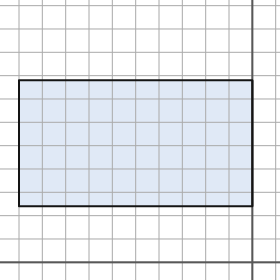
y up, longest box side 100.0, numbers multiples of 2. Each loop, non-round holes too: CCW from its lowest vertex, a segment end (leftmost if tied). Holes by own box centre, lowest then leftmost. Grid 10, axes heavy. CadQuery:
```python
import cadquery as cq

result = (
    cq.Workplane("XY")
    .moveTo(-100.0, 24.0)
    .lineTo(0.0, 24.0)
    .lineTo(0.0, 78.0)
    .lineTo(-100.0, 78.0)
    .close()
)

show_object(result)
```